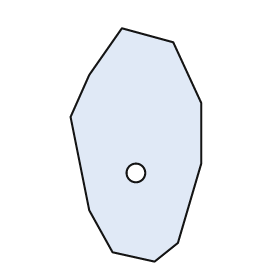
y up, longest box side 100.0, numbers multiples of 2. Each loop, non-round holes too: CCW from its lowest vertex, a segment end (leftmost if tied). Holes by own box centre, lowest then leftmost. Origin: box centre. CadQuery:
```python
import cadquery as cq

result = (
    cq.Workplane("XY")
    .moveTo(8.0, -50.0)
    .lineTo(18.0, -42.0)
    .lineTo(28.0, -8.0)
    .lineTo(28.0, 18.0)
    .lineTo(16.0, 44.0)
    .lineTo(-6.0, 50.0)
    .lineTo(-20.0, 30.0)
    .lineTo(-28.0, 12.0)
    .lineTo(-20.0, -28.0)
    .lineTo(-10.0, -46.0)
    .close()
    .moveTo(0.0, -12.0)
    .circle(4.0)
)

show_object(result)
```